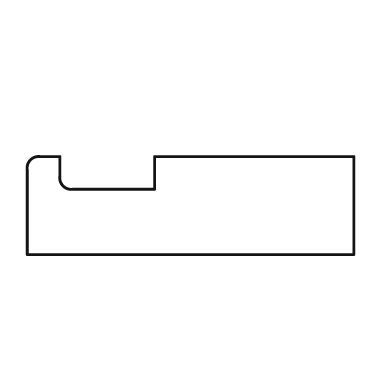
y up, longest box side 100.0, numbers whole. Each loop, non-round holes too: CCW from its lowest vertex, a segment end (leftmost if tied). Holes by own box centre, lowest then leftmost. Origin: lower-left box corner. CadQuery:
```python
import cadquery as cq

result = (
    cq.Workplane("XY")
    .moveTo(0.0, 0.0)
    .lineTo(100.0, 0.0)
    .lineTo(100.0, 30.0)
    .lineTo(39.0, 30.0)
    .lineTo(39.0, 20.0)
    .lineTo(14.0, 20.0)
    .threePointArc((11.0, 21.0), (10.0, 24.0))
    .lineTo(10.0, 30.0)
    .lineTo(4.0, 30.0)
    .threePointArc((1.0, 29.0), (0.0, 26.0))
    .close()
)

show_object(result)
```